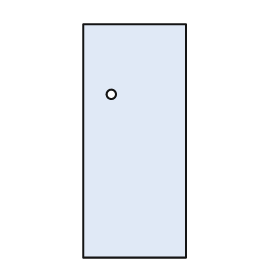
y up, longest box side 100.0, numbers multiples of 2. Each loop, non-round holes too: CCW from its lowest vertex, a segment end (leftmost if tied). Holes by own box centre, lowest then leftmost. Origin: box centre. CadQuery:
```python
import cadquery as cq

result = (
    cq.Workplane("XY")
    .moveTo(-22.0, -50.0)
    .lineTo(22.0, -50.0)
    .lineTo(22.0, 50.0)
    .lineTo(-22.0, 50.0)
    .close()
    .moveTo(-10.0, 20.0)
    .circle(2.0)
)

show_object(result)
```